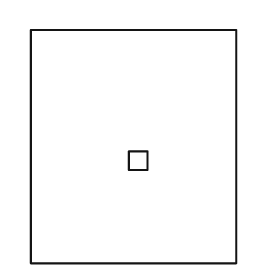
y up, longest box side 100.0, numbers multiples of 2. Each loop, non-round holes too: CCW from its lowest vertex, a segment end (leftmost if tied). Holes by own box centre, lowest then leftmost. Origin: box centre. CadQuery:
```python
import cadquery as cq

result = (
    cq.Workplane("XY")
    .moveTo(-44.0, -50.0)
    .lineTo(44.0, -50.0)
    .lineTo(44.0, 50.0)
    .lineTo(-44.0, 50.0)
    .close()
    .moveTo(-2.0, -10.0)
    .lineTo(6.0, -10.0)
    .lineTo(6.0, -2.0)
    .lineTo(-2.0, -2.0)
    .close()
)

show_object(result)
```